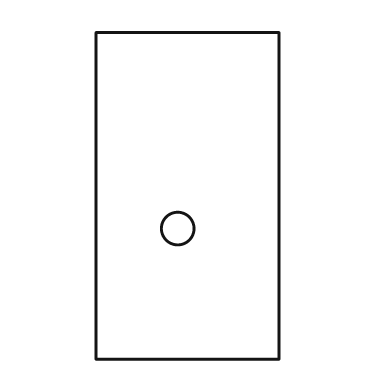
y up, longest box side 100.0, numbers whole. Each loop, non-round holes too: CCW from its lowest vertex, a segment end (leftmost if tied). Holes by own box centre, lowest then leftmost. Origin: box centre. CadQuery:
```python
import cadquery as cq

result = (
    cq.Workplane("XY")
    .moveTo(-28.0, -50.0)
    .lineTo(28.0, -50.0)
    .lineTo(28.0, 50.0)
    .lineTo(-28.0, 50.0)
    .close()
    .moveTo(-3.0, -10.0)
    .circle(5.0)
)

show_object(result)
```